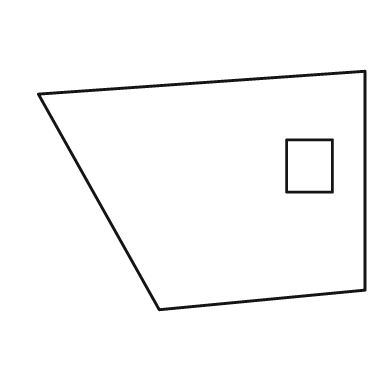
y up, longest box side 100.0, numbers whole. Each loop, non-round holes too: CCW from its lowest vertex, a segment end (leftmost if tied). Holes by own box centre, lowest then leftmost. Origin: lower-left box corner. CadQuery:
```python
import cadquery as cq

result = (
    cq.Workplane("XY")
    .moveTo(37.0, 0.0)
    .lineTo(100.0, 6.0)
    .lineTo(100.0, 73.0)
    .lineTo(0.0, 66.0)
    .close()
    .moveTo(76.0, 36.0)
    .lineTo(90.0, 36.0)
    .lineTo(90.0, 52.0)
    .lineTo(76.0, 52.0)
    .close()
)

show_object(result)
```